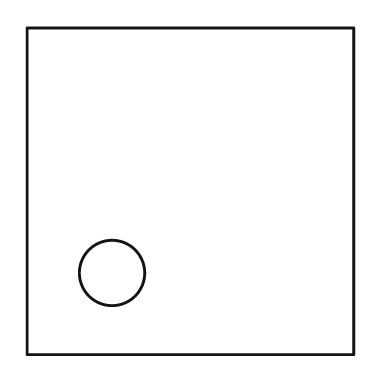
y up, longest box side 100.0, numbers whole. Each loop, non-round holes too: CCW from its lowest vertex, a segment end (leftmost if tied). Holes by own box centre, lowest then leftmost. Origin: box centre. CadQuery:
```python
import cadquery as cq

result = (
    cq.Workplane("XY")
    .moveTo(-50.0, -50.0)
    .lineTo(50.0, -50.0)
    .lineTo(50.0, 50.0)
    .lineTo(-50.0, 50.0)
    .close()
    .moveTo(-24.0, -25.0)
    .circle(10.0)
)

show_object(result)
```